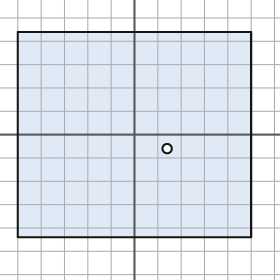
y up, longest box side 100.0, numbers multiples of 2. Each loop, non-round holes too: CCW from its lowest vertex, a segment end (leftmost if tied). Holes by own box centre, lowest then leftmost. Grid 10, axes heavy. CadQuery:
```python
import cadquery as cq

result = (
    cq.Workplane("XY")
    .moveTo(-50.0, -44.0)
    .lineTo(50.0, -44.0)
    .lineTo(50.0, 44.0)
    .lineTo(-50.0, 44.0)
    .close()
    .moveTo(14.0, -6.0)
    .circle(2.0)
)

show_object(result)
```